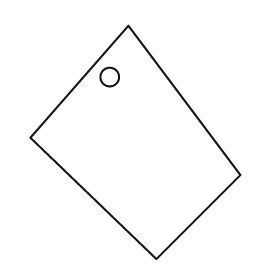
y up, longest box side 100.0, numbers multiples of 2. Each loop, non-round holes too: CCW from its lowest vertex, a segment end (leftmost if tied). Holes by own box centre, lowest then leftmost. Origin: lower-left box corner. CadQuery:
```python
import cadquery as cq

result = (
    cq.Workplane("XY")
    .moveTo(54.0, 0.0)
    .lineTo(90.0, 36.0)
    .lineTo(42.0, 100.0)
    .lineTo(0.0, 52.0)
    .close()
    .moveTo(34.0, 78.0)
    .circle(4.0)
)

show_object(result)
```